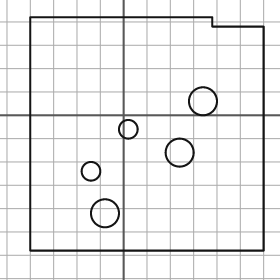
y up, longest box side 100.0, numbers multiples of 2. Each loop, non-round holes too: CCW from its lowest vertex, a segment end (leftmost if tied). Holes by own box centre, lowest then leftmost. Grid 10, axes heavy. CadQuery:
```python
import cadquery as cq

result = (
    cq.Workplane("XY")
    .moveTo(-40.0, -58.0)
    .lineTo(60.0, -58.0)
    .lineTo(60.0, 38.0)
    .lineTo(38.0, 38.0)
    .lineTo(38.0, 42.0)
    .lineTo(-40.0, 42.0)
    .close()
    .moveTo(-8.0, -42.0)
    .circle(6.0)
    .moveTo(-14.0, -24.0)
    .circle(4.0)
    .moveTo(24.0, -16.0)
    .circle(6.0)
    .moveTo(2.0, -6.0)
    .circle(4.0)
    .moveTo(34.0, 6.0)
    .circle(6.0)
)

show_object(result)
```